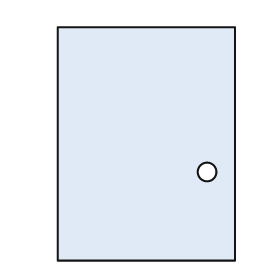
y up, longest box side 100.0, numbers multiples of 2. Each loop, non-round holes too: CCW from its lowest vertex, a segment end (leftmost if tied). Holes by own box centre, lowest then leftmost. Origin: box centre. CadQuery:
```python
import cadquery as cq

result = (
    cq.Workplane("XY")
    .moveTo(-38.0, -50.0)
    .lineTo(38.0, -50.0)
    .lineTo(38.0, 50.0)
    .lineTo(-38.0, 50.0)
    .close()
    .moveTo(26.0, -12.0)
    .circle(4.0)
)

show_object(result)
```